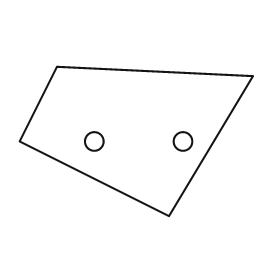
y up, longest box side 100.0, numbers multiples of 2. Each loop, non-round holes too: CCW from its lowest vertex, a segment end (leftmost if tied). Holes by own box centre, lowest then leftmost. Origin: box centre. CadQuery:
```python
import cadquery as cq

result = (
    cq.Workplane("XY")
    .moveTo(14.0, -32.0)
    .lineTo(50.0, 28.0)
    .lineTo(-34.0, 32.0)
    .lineTo(-50.0, 0.0)
    .close()
    .moveTo(-18.0, 0.0)
    .circle(4.0)
    .moveTo(20.0, 0.0)
    .circle(4.0)
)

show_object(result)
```